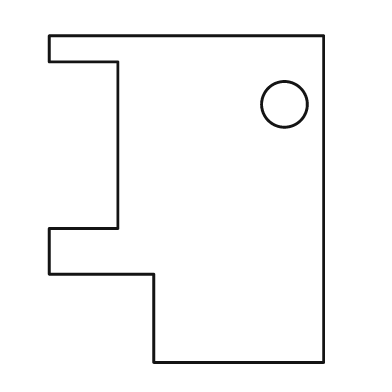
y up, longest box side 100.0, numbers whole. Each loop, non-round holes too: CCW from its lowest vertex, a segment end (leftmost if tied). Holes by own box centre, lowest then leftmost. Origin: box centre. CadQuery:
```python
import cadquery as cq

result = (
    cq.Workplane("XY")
    .moveTo(-10.0, -50.0)
    .lineTo(42.0, -50.0)
    .lineTo(42.0, 50.0)
    .lineTo(-42.0, 50.0)
    .lineTo(-42.0, 42.0)
    .lineTo(-21.0, 42.0)
    .lineTo(-21.0, -9.0)
    .lineTo(-42.0, -9.0)
    .lineTo(-42.0, -23.0)
    .lineTo(-10.0, -23.0)
    .close()
    .moveTo(30.0, 29.0)
    .circle(7.0)
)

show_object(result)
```